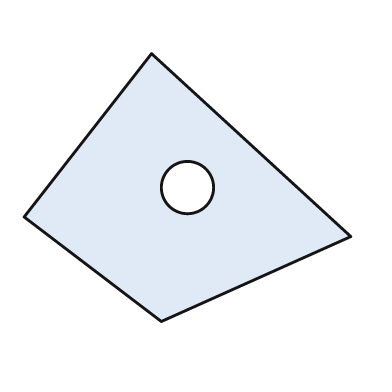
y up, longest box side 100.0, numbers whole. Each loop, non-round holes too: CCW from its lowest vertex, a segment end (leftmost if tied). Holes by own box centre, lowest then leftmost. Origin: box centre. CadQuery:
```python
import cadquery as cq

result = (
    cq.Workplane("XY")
    .moveTo(-8.0, -41.0)
    .lineTo(50.0, -15.0)
    .lineTo(-11.0, 41.0)
    .lineTo(-50.0, -9.0)
    .close()
    .moveTo(0.0, 0.0)
    .circle(8.0)
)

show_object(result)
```